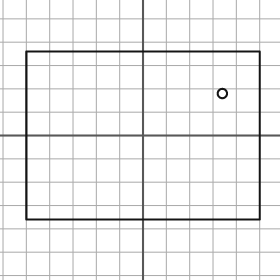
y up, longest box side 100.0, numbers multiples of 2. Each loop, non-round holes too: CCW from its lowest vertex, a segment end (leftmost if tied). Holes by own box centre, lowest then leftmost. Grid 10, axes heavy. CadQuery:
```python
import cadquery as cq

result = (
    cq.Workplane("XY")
    .moveTo(-50.0, -36.0)
    .lineTo(50.0, -36.0)
    .lineTo(50.0, 36.0)
    .lineTo(-50.0, 36.0)
    .close()
    .moveTo(34.0, 18.0)
    .circle(2.0)
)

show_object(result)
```